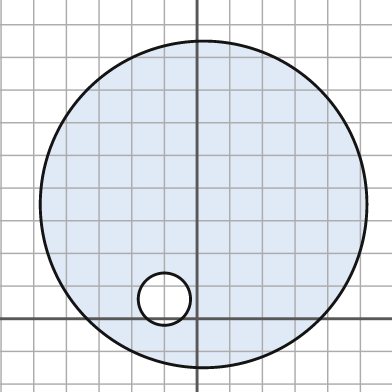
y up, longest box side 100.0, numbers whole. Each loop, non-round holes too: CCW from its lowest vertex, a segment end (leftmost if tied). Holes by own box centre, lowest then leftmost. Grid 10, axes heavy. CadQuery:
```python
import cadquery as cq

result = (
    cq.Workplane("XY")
    .moveTo(2.0, 35.0)
    .circle(50.0)
    .moveTo(-10.0, 6.0)
    .circle(8.0)
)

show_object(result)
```